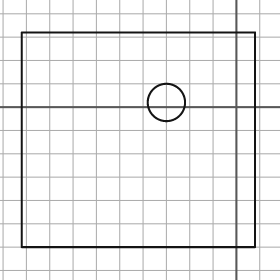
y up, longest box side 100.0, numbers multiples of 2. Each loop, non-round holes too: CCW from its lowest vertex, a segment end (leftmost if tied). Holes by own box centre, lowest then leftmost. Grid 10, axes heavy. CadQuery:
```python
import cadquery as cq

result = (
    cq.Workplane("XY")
    .moveTo(-92.0, -60.0)
    .lineTo(8.0, -60.0)
    .lineTo(8.0, 32.0)
    .lineTo(-92.0, 32.0)
    .close()
    .moveTo(-30.0, 2.0)
    .circle(8.0)
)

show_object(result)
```